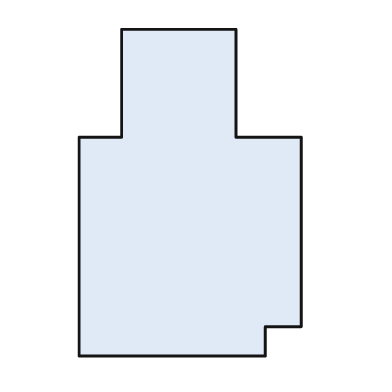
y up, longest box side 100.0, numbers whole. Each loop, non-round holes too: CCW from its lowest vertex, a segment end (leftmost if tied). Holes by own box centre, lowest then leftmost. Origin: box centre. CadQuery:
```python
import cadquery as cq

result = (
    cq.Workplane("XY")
    .moveTo(-34.0, -50.0)
    .lineTo(23.0, -50.0)
    .lineTo(23.0, -41.0)
    .lineTo(34.0, -41.0)
    .lineTo(34.0, 17.0)
    .lineTo(14.0, 17.0)
    .lineTo(14.0, 50.0)
    .lineTo(-21.0, 50.0)
    .lineTo(-21.0, 17.0)
    .lineTo(-34.0, 17.0)
    .close()
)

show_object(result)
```